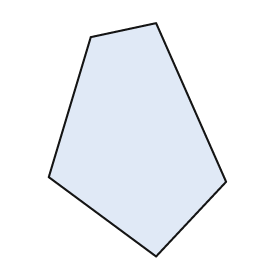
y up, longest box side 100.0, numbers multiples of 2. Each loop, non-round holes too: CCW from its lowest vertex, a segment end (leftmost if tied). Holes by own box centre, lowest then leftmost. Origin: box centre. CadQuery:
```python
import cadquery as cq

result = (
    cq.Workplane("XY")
    .moveTo(8.0, -50.0)
    .lineTo(38.0, -18.0)
    .lineTo(8.0, 50.0)
    .lineTo(-20.0, 44.0)
    .lineTo(-38.0, -16.0)
    .close()
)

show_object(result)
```